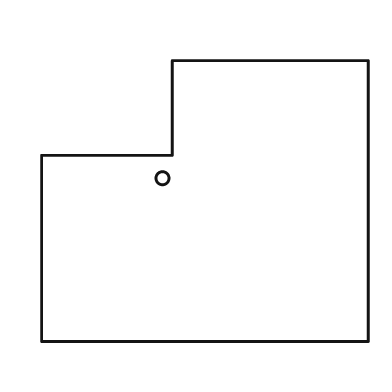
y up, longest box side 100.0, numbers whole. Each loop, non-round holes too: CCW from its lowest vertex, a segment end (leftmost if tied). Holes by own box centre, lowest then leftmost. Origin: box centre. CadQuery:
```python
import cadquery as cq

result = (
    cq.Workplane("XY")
    .moveTo(-50.0, -43.0)
    .lineTo(50.0, -43.0)
    .lineTo(50.0, 43.0)
    .lineTo(-10.0, 43.0)
    .lineTo(-10.0, 14.0)
    .lineTo(-50.0, 14.0)
    .close()
    .moveTo(-13.0, 7.0)
    .circle(2.0)
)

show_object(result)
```